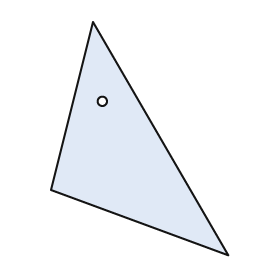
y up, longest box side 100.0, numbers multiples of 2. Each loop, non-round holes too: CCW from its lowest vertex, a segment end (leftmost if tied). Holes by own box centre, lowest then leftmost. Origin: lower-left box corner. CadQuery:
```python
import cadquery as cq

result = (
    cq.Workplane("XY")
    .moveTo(76.0, 0.0)
    .lineTo(18.0, 100.0)
    .lineTo(0.0, 28.0)
    .close()
    .moveTo(22.0, 66.0)
    .circle(2.0)
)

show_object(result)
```